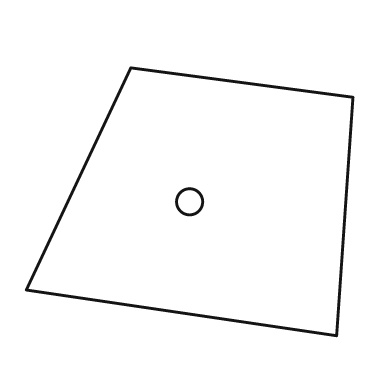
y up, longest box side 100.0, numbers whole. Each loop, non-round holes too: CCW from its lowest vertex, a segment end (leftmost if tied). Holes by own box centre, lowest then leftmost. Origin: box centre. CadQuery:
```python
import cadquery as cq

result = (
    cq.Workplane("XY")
    .moveTo(45.0, -41.0)
    .lineTo(50.0, 32.0)
    .lineTo(-18.0, 41.0)
    .lineTo(-50.0, -27.0)
    .close()
    .moveTo(0.0, 0.0)
    .circle(4.0)
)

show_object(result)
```